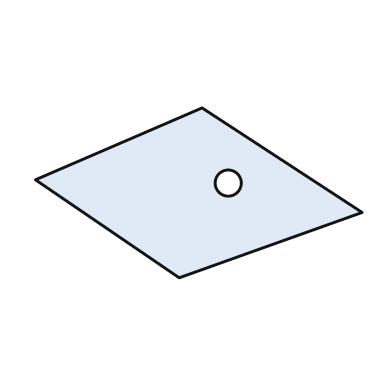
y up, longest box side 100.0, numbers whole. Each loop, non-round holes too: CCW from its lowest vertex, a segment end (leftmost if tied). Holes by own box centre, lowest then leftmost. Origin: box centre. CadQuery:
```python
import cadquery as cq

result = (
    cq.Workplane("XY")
    .moveTo(-6.0, -26.0)
    .lineTo(50.0, -6.0)
    .lineTo(1.0, 26.0)
    .lineTo(-50.0, 4.0)
    .close()
    .moveTo(9.0, 3.0)
    .circle(4.0)
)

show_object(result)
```